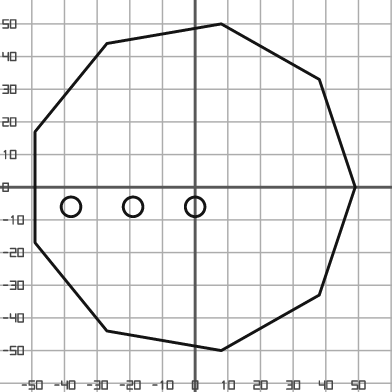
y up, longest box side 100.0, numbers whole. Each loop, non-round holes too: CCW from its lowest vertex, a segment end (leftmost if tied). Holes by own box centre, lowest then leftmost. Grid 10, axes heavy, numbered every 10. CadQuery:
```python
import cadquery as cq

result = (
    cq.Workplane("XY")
    .moveTo(8.0, -50.0)
    .lineTo(38.0, -33.0)
    .lineTo(49.0, 0.0)
    .lineTo(38.0, 33.0)
    .lineTo(8.0, 50.0)
    .lineTo(-27.0, 44.0)
    .lineTo(-49.0, 17.0)
    .lineTo(-49.0, -17.0)
    .lineTo(-27.0, -44.0)
    .close()
    .moveTo(-38.0, -6.0)
    .circle(3.0)
    .moveTo(-19.0, -6.0)
    .circle(3.0)
    .moveTo(0.0, -6.0)
    .circle(3.0)
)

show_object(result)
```